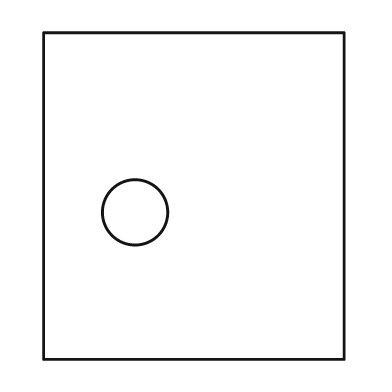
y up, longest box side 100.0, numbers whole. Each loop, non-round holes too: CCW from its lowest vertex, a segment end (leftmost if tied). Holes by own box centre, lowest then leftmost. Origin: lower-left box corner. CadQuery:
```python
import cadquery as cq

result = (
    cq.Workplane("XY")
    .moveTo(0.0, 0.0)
    .lineTo(92.0, 0.0)
    .lineTo(92.0, 100.0)
    .lineTo(0.0, 100.0)
    .close()
    .moveTo(28.0, 45.0)
    .circle(10.0)
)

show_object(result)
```